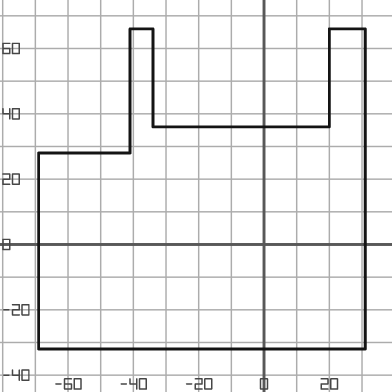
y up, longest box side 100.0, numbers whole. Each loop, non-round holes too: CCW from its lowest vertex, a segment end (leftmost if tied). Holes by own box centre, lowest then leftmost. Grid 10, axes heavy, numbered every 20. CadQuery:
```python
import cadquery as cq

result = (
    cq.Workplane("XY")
    .moveTo(-69.0, -32.0)
    .lineTo(31.0, -32.0)
    .lineTo(31.0, 66.0)
    .lineTo(20.0, 66.0)
    .lineTo(20.0, 36.0)
    .lineTo(-34.0, 36.0)
    .lineTo(-34.0, 66.0)
    .lineTo(-41.0, 66.0)
    .lineTo(-41.0, 28.0)
    .lineTo(-69.0, 28.0)
    .close()
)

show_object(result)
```